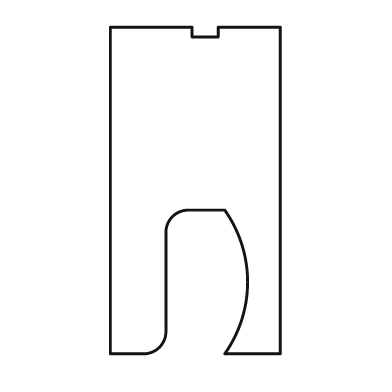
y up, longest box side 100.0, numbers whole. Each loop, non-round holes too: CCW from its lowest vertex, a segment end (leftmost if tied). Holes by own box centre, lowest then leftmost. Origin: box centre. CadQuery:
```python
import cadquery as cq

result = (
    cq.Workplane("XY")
    .moveTo(-26.0, -50.0)
    .lineTo(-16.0, -50.0)
    .threePointArc((-11.0, -48.0), (-9.0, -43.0))
    .lineTo(-9.0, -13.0)
    .threePointArc((-7.0, -8.0), (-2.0, -6.0))
    .lineTo(9.0, -6.0)
    .threePointArc((16.0, -28.0), (9.0, -50.0))
    .lineTo(26.0, -50.0)
    .lineTo(26.0, 50.0)
    .lineTo(7.0, 50.0)
    .lineTo(7.0, 47.0)
    .lineTo(-1.0, 47.0)
    .lineTo(-1.0, 50.0)
    .lineTo(-26.0, 50.0)
    .close()
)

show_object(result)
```